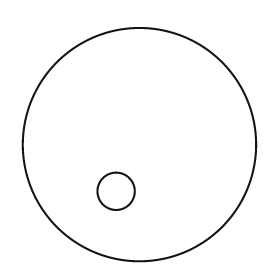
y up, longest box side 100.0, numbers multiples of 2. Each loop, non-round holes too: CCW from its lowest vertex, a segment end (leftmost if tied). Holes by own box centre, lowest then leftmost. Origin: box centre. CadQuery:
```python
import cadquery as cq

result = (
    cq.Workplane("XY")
    .moveTo(0.0, 0.0)
    .circle(50.0)
    .moveTo(-10.0, -20.0)
    .circle(8.0)
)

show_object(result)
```